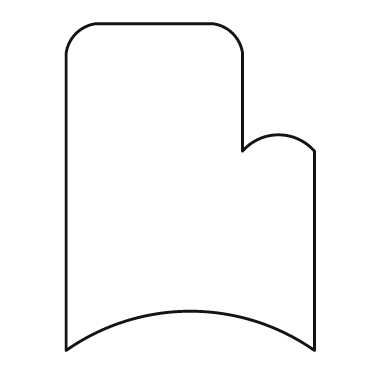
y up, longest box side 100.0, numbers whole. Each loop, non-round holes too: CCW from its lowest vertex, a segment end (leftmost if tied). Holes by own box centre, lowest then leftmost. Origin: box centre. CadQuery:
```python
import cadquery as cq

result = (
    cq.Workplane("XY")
    .moveTo(-38.0, -50.0)
    .threePointArc((0.0, -38.0), (38.0, -50.0))
    .lineTo(38.0, 11.0)
    .threePointArc((27.0, 16.0), (16.0, 11.0))
    .lineTo(16.0, 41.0)
    .threePointArc((13.0, 47.0), (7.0, 50.0))
    .lineTo(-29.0, 50.0)
    .threePointArc((-35.0, 47.0), (-38.0, 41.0))
    .close()
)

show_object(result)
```